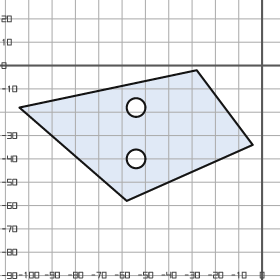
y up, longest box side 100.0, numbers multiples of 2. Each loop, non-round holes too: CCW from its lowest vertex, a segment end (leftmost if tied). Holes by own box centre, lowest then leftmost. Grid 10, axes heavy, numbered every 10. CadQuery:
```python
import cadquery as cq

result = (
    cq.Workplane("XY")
    .moveTo(-58.0, -58.0)
    .lineTo(-4.0, -34.0)
    .lineTo(-28.0, -2.0)
    .lineTo(-104.0, -18.0)
    .close()
    .moveTo(-54.0, -40.0)
    .circle(4.0)
    .moveTo(-54.0, -18.0)
    .circle(4.0)
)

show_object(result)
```